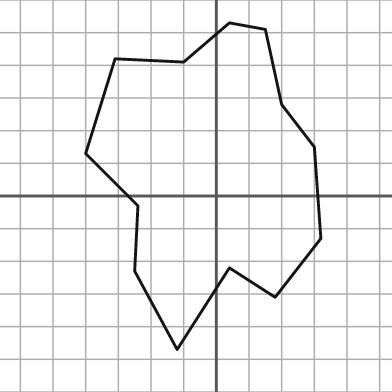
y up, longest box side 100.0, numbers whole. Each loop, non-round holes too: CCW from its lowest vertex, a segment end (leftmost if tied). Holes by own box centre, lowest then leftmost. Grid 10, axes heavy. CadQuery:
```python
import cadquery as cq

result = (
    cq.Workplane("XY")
    .moveTo(-12.0, -47.0)
    .lineTo(4.0, -22.0)
    .lineTo(18.0, -31.0)
    .lineTo(32.0, -13.0)
    .lineTo(30.0, 15.0)
    .lineTo(20.0, 28.0)
    .lineTo(15.0, 51.0)
    .lineTo(4.0, 53.0)
    .lineTo(-10.0, 41.0)
    .lineTo(-31.0, 42.0)
    .lineTo(-40.0, 13.0)
    .lineTo(-24.0, -3.0)
    .lineTo(-25.0, -23.0)
    .close()
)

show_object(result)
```